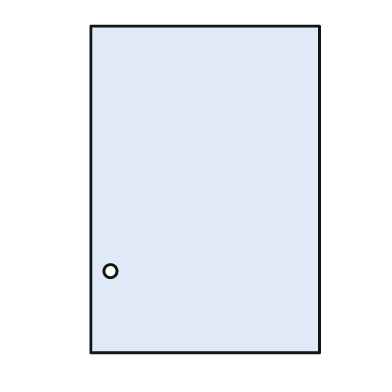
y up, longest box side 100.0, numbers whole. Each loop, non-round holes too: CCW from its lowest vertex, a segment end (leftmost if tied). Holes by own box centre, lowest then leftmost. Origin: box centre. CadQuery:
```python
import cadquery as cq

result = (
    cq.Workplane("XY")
    .moveTo(-35.0, -50.0)
    .lineTo(35.0, -50.0)
    .lineTo(35.0, 50.0)
    .lineTo(-35.0, 50.0)
    .close()
    .moveTo(-29.0, -25.0)
    .circle(2.0)
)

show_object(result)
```